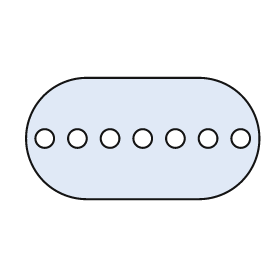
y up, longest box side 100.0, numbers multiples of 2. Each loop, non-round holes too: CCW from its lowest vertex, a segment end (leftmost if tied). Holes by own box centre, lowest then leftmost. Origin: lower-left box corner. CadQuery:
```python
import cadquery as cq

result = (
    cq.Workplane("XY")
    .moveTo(26.0, 0.0)
    .lineTo(74.0, 0.0)
    .threePointArc((100.0, 26.0), (74.0, 52.0))
    .lineTo(26.0, 52.0)
    .threePointArc((0.0, 26.0), (26.0, 0.0))
    .close()
    .moveTo(8.0, 26.0)
    .circle(4.0)
    .moveTo(22.0, 26.0)
    .circle(4.0)
    .moveTo(36.0, 26.0)
    .circle(4.0)
    .moveTo(50.0, 26.0)
    .circle(4.0)
    .moveTo(64.0, 26.0)
    .circle(4.0)
    .moveTo(78.0, 26.0)
    .circle(4.0)
    .moveTo(92.0, 26.0)
    .circle(4.0)
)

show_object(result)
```